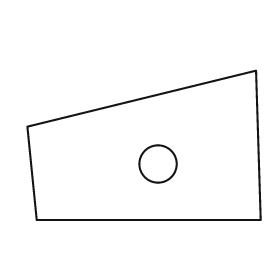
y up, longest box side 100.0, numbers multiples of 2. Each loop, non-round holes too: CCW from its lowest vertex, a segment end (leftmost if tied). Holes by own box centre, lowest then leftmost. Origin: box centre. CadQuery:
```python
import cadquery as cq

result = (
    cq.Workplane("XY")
    .moveTo(-46.0, -32.0)
    .lineTo(50.0, -32.0)
    .lineTo(48.0, 32.0)
    .lineTo(-50.0, 8.0)
    .close()
    .moveTo(6.0, -8.0)
    .circle(8.0)
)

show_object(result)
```